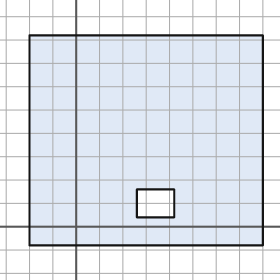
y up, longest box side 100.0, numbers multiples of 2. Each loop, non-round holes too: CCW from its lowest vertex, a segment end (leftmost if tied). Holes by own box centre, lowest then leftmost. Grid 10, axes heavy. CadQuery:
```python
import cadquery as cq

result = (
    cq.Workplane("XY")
    .moveTo(-20.0, -8.0)
    .lineTo(80.0, -8.0)
    .lineTo(80.0, 82.0)
    .lineTo(-20.0, 82.0)
    .close()
    .moveTo(26.0, 4.0)
    .lineTo(42.0, 4.0)
    .lineTo(42.0, 16.0)
    .lineTo(26.0, 16.0)
    .close()
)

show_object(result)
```